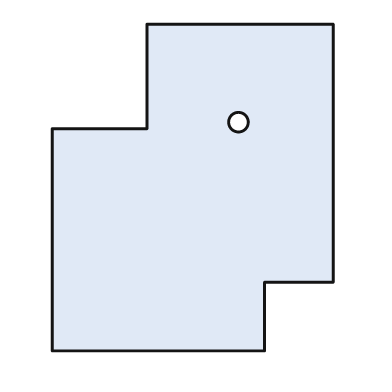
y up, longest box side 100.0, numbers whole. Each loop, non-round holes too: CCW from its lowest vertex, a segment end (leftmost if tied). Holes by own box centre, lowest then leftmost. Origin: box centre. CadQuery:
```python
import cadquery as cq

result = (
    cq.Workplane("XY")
    .moveTo(-43.0, -50.0)
    .lineTo(22.0, -50.0)
    .lineTo(22.0, -29.0)
    .lineTo(43.0, -29.0)
    .lineTo(43.0, 50.0)
    .lineTo(-14.0, 50.0)
    .lineTo(-14.0, 18.0)
    .lineTo(-43.0, 18.0)
    .close()
    .moveTo(14.0, 20.0)
    .circle(3.0)
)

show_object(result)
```